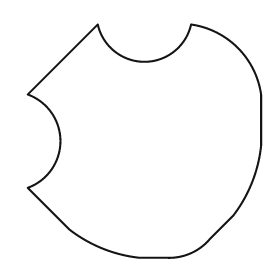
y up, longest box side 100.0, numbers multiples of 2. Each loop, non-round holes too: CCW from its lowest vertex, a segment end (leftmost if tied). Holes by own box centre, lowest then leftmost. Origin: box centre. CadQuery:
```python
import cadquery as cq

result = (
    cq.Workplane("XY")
    .moveTo(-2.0, -50.0)
    .lineTo(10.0, -50.0)
    .threePointArc((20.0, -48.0), (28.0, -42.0))
    .lineTo(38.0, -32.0)
    .threePointArc((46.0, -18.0), (50.0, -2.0))
    .lineTo(50.0, 20.0)
    .threePointArc((40.0, 40.0), (20.0, 50.0))
    .threePointArc((0.0, 34.0), (-20.0, 50.0))
    .lineTo(-50.0, 20.0)
    .threePointArc((-36.0, 0.0), (-50.0, -20.0))
    .lineTo(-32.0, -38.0)
    .threePointArc((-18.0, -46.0), (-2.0, -50.0))
    .close()
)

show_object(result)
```